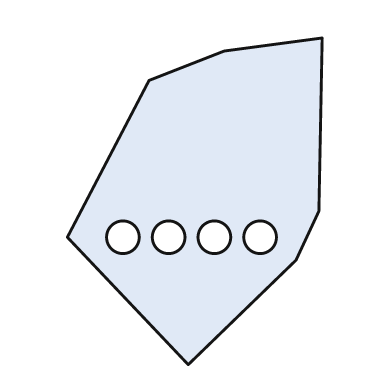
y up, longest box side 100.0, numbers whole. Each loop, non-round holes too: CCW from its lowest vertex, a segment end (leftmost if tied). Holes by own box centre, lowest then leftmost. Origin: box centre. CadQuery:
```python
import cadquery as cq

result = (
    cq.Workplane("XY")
    .moveTo(-2.0, -50.0)
    .lineTo(31.0, -18.0)
    .lineTo(38.0, -3.0)
    .lineTo(39.0, 50.0)
    .lineTo(9.0, 46.0)
    .lineTo(-14.0, 37.0)
    .lineTo(-39.0, -11.0)
    .close()
    .moveTo(-22.0, -11.0)
    .circle(5.0)
    .moveTo(-8.0, -11.0)
    .circle(5.0)
    .moveTo(6.0, -11.0)
    .circle(5.0)
    .moveTo(20.0, -11.0)
    .circle(5.0)
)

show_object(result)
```